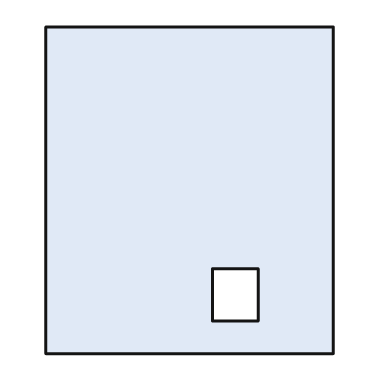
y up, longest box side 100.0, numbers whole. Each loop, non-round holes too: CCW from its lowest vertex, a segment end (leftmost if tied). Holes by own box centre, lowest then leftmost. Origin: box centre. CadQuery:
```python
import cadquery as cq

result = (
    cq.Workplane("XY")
    .moveTo(-44.0, -50.0)
    .lineTo(44.0, -50.0)
    .lineTo(44.0, 50.0)
    .lineTo(-44.0, 50.0)
    .close()
    .moveTo(7.0, -40.0)
    .lineTo(21.0, -40.0)
    .lineTo(21.0, -24.0)
    .lineTo(7.0, -24.0)
    .close()
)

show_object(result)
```